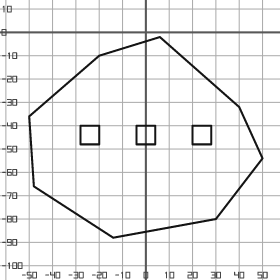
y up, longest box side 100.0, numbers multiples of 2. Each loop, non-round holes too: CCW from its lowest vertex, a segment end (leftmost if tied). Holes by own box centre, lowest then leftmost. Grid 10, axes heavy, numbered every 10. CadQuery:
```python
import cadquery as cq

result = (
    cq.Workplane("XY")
    .moveTo(-14.0, -88.0)
    .lineTo(30.0, -80.0)
    .lineTo(50.0, -54.0)
    .lineTo(40.0, -32.0)
    .lineTo(6.0, -2.0)
    .lineTo(-20.0, -10.0)
    .lineTo(-50.0, -36.0)
    .lineTo(-48.0, -66.0)
    .close()
    .moveTo(-28.0, -48.0)
    .lineTo(-20.0, -48.0)
    .lineTo(-20.0, -40.0)
    .lineTo(-28.0, -40.0)
    .close()
    .moveTo(-4.0, -48.0)
    .lineTo(4.0, -48.0)
    .lineTo(4.0, -40.0)
    .lineTo(-4.0, -40.0)
    .close()
    .moveTo(20.0, -48.0)
    .lineTo(28.0, -48.0)
    .lineTo(28.0, -40.0)
    .lineTo(20.0, -40.0)
    .close()
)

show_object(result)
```